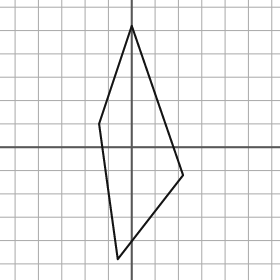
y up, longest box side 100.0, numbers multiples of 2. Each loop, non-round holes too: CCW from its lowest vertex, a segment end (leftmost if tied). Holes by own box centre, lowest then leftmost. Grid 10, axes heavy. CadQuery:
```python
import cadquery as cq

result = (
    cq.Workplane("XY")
    .moveTo(-6.0, -48.0)
    .lineTo(22.0, -12.0)
    .lineTo(0.0, 52.0)
    .lineTo(-14.0, 10.0)
    .close()
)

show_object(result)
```